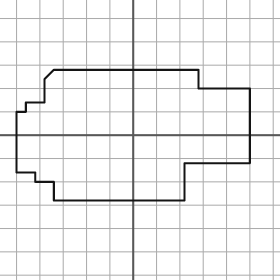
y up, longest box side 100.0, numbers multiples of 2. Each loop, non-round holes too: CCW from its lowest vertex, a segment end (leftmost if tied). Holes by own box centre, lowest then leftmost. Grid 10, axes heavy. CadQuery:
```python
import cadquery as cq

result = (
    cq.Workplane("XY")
    .moveTo(-34.0, -28.0)
    .lineTo(22.0, -28.0)
    .lineTo(22.0, -12.0)
    .lineTo(50.0, -12.0)
    .lineTo(50.0, 20.0)
    .lineTo(28.0, 20.0)
    .lineTo(28.0, 28.0)
    .lineTo(-34.0, 28.0)
    .lineTo(-38.0, 24.0)
    .lineTo(-38.0, 14.0)
    .lineTo(-46.0, 14.0)
    .lineTo(-46.0, 10.0)
    .lineTo(-50.0, 10.0)
    .lineTo(-50.0, -16.0)
    .lineTo(-42.0, -16.0)
    .lineTo(-42.0, -20.0)
    .lineTo(-34.0, -20.0)
    .close()
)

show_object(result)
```